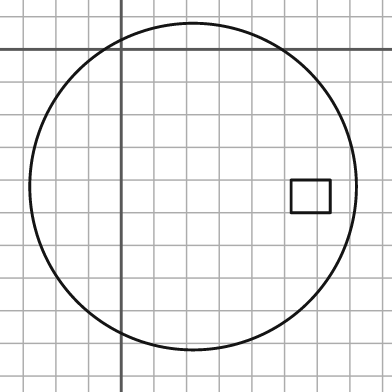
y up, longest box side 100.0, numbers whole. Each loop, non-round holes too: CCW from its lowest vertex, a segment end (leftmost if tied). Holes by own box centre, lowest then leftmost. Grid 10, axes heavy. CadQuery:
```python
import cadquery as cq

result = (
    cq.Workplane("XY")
    .moveTo(22.0, -42.0)
    .circle(50.0)
    .moveTo(52.0, -50.0)
    .lineTo(64.0, -50.0)
    .lineTo(64.0, -40.0)
    .lineTo(52.0, -40.0)
    .close()
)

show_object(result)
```